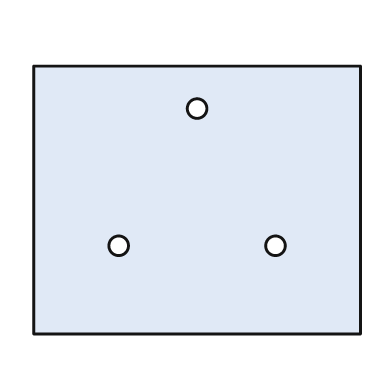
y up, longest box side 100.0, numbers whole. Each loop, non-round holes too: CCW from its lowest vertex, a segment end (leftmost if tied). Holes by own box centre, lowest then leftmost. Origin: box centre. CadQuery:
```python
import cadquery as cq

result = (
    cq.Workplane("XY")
    .moveTo(-50.0, -41.0)
    .lineTo(50.0, -41.0)
    .lineTo(50.0, 41.0)
    .lineTo(-50.0, 41.0)
    .close()
    .moveTo(-24.0, -14.0)
    .circle(3.0)
    .moveTo(24.0, -14.0)
    .circle(3.0)
    .moveTo(0.0, 28.0)
    .circle(3.0)
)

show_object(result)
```